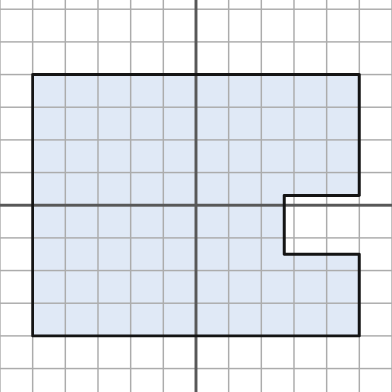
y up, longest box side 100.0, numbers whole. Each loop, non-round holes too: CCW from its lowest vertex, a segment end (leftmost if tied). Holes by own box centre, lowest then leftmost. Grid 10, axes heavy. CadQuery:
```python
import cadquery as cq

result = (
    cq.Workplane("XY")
    .moveTo(-50.0, -40.0)
    .lineTo(50.0, -40.0)
    .lineTo(50.0, -15.0)
    .lineTo(27.0, -15.0)
    .lineTo(27.0, 3.0)
    .lineTo(50.0, 3.0)
    .lineTo(50.0, 40.0)
    .lineTo(-50.0, 40.0)
    .close()
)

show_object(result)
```